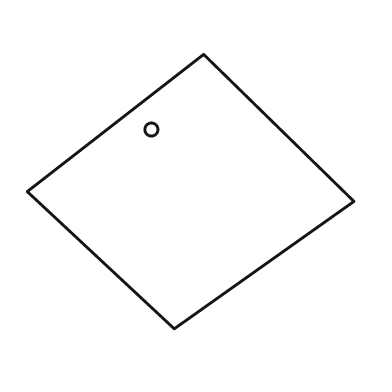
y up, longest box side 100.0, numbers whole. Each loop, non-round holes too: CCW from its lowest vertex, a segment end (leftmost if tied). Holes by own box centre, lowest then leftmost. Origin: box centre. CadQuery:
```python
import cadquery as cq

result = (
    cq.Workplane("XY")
    .moveTo(-5.0, -42.0)
    .lineTo(50.0, -3.0)
    .lineTo(4.0, 42.0)
    .lineTo(-50.0, 0.0)
    .close()
    .moveTo(-12.0, 19.0)
    .circle(2.0)
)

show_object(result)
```